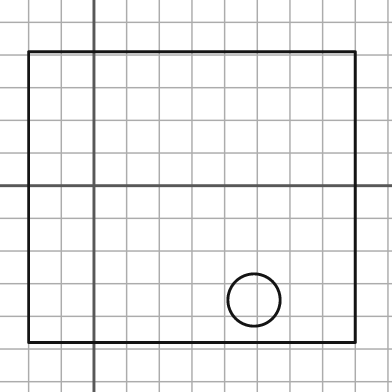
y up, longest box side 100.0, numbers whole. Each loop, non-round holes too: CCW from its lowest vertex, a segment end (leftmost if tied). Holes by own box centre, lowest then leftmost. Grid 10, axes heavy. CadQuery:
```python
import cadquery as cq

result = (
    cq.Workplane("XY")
    .moveTo(-20.0, -48.0)
    .lineTo(80.0, -48.0)
    .lineTo(80.0, 41.0)
    .lineTo(-20.0, 41.0)
    .close()
    .moveTo(49.0, -35.0)
    .circle(8.0)
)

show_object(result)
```